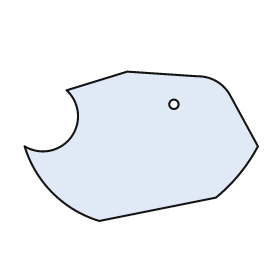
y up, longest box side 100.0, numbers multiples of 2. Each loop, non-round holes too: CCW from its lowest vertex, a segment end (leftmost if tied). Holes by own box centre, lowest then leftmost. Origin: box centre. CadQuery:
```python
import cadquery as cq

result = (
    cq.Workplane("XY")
    .moveTo(-18.0, -32.0)
    .lineTo(32.0, -22.0)
    .threePointArc((42.0, -12.0), (50.0, 0.0))
    .lineTo(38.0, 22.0)
    .threePointArc((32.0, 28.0), (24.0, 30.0))
    .lineTo(-6.0, 32.0)
    .lineTo(-32.0, 24.0)
    .threePointArc((-30.0, 4.0), (-50.0, 0.0))
    .threePointArc((-38.0, -20.0), (-18.0, -32.0))
    .close()
    .moveTo(14.0, 18.0)
    .circle(2.0)
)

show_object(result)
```